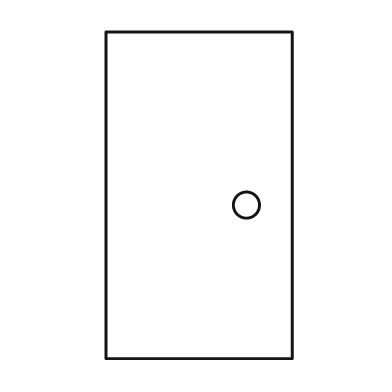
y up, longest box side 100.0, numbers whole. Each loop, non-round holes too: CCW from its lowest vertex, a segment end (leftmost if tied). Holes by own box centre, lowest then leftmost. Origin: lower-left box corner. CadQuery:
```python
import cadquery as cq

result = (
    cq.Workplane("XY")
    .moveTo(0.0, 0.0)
    .lineTo(57.0, 0.0)
    .lineTo(57.0, 100.0)
    .lineTo(0.0, 100.0)
    .close()
    .moveTo(43.0, 47.0)
    .circle(4.0)
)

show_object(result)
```